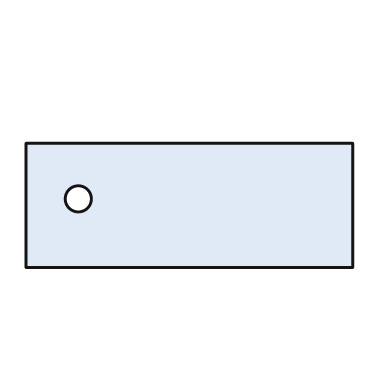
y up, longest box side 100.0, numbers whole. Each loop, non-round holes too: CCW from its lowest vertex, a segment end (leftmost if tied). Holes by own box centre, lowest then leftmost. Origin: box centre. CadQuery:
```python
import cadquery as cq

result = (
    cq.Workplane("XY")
    .moveTo(-50.0, -19.0)
    .lineTo(50.0, -19.0)
    .lineTo(50.0, 19.0)
    .lineTo(-50.0, 19.0)
    .close()
    .moveTo(-34.0, 2.0)
    .circle(4.0)
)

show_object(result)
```